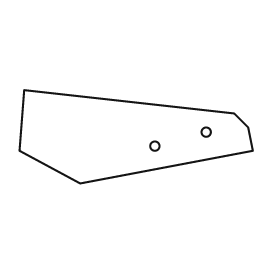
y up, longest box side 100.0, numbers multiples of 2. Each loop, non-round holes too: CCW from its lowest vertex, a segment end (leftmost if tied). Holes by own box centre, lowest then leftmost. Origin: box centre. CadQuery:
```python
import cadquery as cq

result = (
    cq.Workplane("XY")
    .moveTo(-24.0, -20.0)
    .lineTo(50.0, -6.0)
    .lineTo(48.0, 4.0)
    .lineTo(42.0, 10.0)
    .lineTo(-48.0, 20.0)
    .lineTo(-50.0, -6.0)
    .close()
    .moveTo(8.0, -4.0)
    .circle(2.0)
    .moveTo(30.0, 2.0)
    .circle(2.0)
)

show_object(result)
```